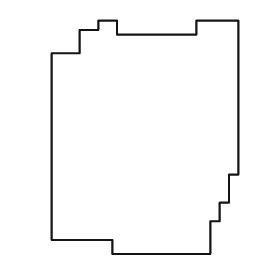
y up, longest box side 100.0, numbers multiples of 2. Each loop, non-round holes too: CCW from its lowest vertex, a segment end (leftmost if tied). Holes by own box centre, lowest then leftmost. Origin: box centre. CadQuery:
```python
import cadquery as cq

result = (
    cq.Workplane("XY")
    .moveTo(-14.0, -50.0)
    .lineTo(28.0, -50.0)
    .lineTo(28.0, -36.0)
    .lineTo(32.0, -36.0)
    .lineTo(32.0, -28.0)
    .lineTo(36.0, -28.0)
    .lineTo(36.0, -16.0)
    .lineTo(40.0, -16.0)
    .lineTo(40.0, 50.0)
    .lineTo(22.0, 50.0)
    .lineTo(22.0, 44.0)
    .lineTo(-12.0, 44.0)
    .lineTo(-12.0, 50.0)
    .lineTo(-20.0, 50.0)
    .lineTo(-20.0, 46.0)
    .lineTo(-28.0, 46.0)
    .lineTo(-28.0, 36.0)
    .lineTo(-40.0, 36.0)
    .lineTo(-40.0, -44.0)
    .lineTo(-14.0, -44.0)
    .close()
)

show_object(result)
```